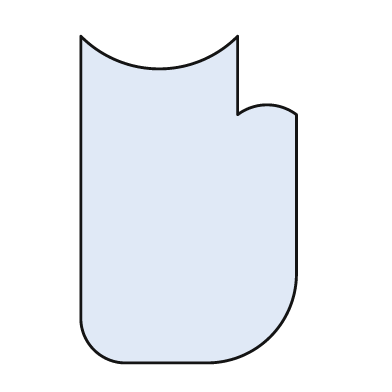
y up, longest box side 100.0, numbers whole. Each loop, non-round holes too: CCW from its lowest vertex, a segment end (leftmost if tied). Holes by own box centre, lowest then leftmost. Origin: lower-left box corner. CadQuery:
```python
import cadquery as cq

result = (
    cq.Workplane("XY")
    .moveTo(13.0, 0.0)
    .lineTo(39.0, 0.0)
    .threePointArc((58.0, 8.0), (66.0, 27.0))
    .lineTo(66.0, 76.0)
    .threePointArc((57.0, 79.0), (48.0, 76.0))
    .lineTo(48.0, 100.0)
    .threePointArc((24.0, 90.0), (0.0, 100.0))
    .lineTo(0.0, 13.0)
    .threePointArc((4.0, 4.0), (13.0, 0.0))
    .close()
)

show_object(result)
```